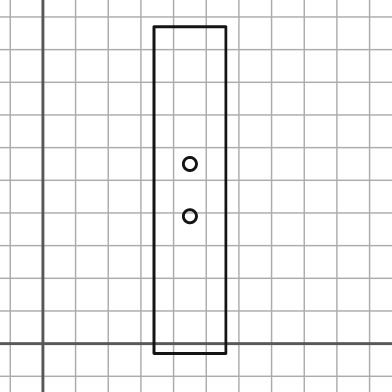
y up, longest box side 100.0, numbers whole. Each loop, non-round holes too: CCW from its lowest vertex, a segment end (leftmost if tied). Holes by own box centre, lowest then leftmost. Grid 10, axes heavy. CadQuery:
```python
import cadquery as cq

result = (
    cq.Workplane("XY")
    .moveTo(34.0, -3.0)
    .lineTo(56.0, -3.0)
    .lineTo(56.0, 97.0)
    .lineTo(34.0, 97.0)
    .close()
    .moveTo(45.0, 39.0)
    .circle(2.0)
    .moveTo(45.0, 55.0)
    .circle(2.0)
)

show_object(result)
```